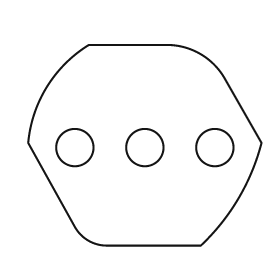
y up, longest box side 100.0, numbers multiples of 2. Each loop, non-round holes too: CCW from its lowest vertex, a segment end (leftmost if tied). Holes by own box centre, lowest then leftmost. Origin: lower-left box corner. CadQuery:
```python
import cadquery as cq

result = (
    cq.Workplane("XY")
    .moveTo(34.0, 0.0)
    .lineTo(74.0, 0.0)
    .threePointArc((90.0, 20.0), (100.0, 44.0))
    .lineTo(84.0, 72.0)
    .threePointArc((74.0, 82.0), (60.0, 86.0))
    .lineTo(26.0, 86.0)
    .threePointArc((8.0, 68.0), (0.0, 44.0))
    .lineTo(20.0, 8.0)
    .threePointArc((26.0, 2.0), (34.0, 0.0))
    .close()
    .moveTo(20.0, 42.0)
    .circle(8.0)
    .moveTo(50.0, 42.0)
    .circle(8.0)
    .moveTo(80.0, 42.0)
    .circle(8.0)
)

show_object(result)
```